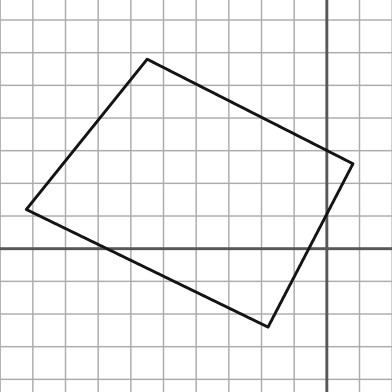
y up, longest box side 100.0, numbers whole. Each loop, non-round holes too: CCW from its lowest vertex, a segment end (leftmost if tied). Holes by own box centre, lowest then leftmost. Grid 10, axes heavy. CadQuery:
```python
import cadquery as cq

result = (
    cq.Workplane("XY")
    .moveTo(-18.0, -24.0)
    .lineTo(8.0, 26.0)
    .lineTo(-55.0, 58.0)
    .lineTo(-92.0, 12.0)
    .close()
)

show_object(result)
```